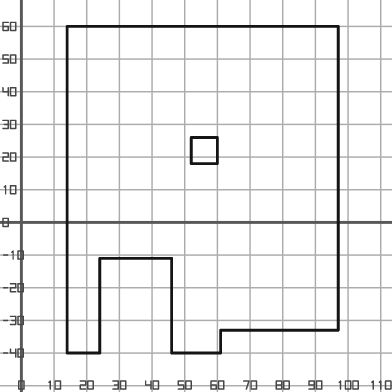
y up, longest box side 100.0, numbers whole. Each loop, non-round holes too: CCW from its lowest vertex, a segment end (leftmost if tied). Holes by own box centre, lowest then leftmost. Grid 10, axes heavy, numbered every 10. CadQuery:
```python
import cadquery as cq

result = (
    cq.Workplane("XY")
    .moveTo(14.0, -40.0)
    .lineTo(24.0, -40.0)
    .lineTo(24.0, -11.0)
    .lineTo(46.0, -11.0)
    .lineTo(46.0, -40.0)
    .lineTo(61.0, -40.0)
    .lineTo(61.0, -33.0)
    .lineTo(97.0, -33.0)
    .lineTo(97.0, 60.0)
    .lineTo(14.0, 60.0)
    .close()
    .moveTo(52.0, 18.0)
    .lineTo(60.0, 18.0)
    .lineTo(60.0, 26.0)
    .lineTo(52.0, 26.0)
    .close()
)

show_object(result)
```